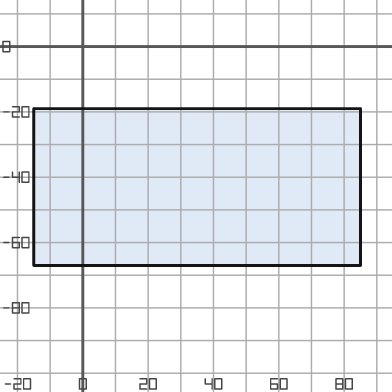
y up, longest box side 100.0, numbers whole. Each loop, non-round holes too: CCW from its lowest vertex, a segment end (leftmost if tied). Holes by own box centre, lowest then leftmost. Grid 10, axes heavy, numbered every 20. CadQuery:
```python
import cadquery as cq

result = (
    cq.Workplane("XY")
    .moveTo(-15.0, -67.0)
    .lineTo(85.0, -67.0)
    .lineTo(85.0, -19.0)
    .lineTo(-15.0, -19.0)
    .close()
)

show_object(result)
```